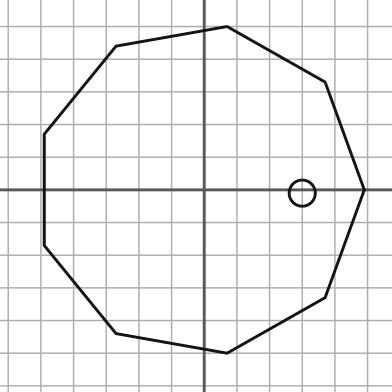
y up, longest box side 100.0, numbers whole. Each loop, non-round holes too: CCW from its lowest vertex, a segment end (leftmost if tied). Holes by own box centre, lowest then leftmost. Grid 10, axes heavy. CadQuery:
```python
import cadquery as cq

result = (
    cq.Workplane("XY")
    .moveTo(7.0, -50.0)
    .lineTo(37.0, -33.0)
    .lineTo(49.0, 0.0)
    .lineTo(37.0, 33.0)
    .lineTo(7.0, 50.0)
    .lineTo(-27.0, 44.0)
    .lineTo(-49.0, 17.0)
    .lineTo(-49.0, -17.0)
    .lineTo(-27.0, -44.0)
    .close()
    .moveTo(30.0, -1.0)
    .circle(4.0)
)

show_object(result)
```